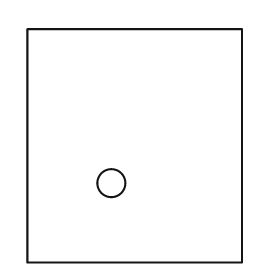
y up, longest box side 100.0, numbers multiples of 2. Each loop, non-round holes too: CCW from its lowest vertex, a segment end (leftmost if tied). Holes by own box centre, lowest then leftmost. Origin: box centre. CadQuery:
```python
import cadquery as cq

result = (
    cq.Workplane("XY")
    .moveTo(-46.0, -50.0)
    .lineTo(46.0, -50.0)
    .lineTo(46.0, 50.0)
    .lineTo(-46.0, 50.0)
    .close()
    .moveTo(-10.0, -16.0)
    .circle(6.0)
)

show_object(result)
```